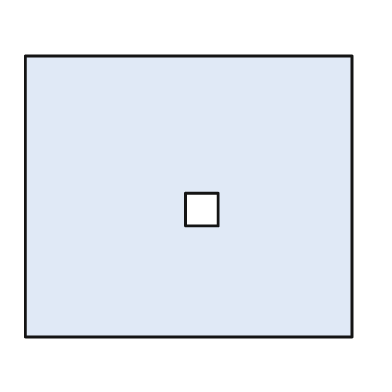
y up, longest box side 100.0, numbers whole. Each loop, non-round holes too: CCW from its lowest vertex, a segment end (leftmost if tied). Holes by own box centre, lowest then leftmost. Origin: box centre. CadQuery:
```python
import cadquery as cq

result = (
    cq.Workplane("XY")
    .moveTo(-50.0, -43.0)
    .lineTo(50.0, -43.0)
    .lineTo(50.0, 43.0)
    .lineTo(-50.0, 43.0)
    .close()
    .moveTo(-1.0, -9.0)
    .lineTo(9.0, -9.0)
    .lineTo(9.0, 1.0)
    .lineTo(-1.0, 1.0)
    .close()
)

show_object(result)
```